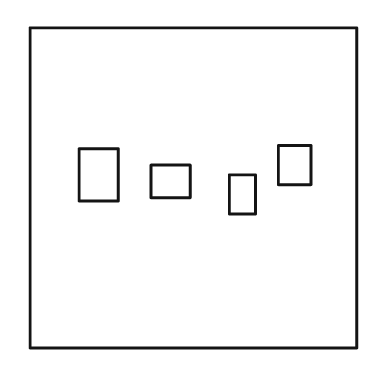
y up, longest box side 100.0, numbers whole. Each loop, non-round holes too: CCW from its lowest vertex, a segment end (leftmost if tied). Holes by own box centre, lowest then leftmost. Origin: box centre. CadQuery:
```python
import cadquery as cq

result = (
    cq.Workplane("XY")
    .moveTo(-50.0, -49.0)
    .lineTo(50.0, -49.0)
    .lineTo(50.0, 49.0)
    .lineTo(-50.0, 49.0)
    .close()
    .moveTo(11.0, -8.0)
    .lineTo(19.0, -8.0)
    .lineTo(19.0, 4.0)
    .lineTo(11.0, 4.0)
    .close()
    .moveTo(-13.0, -3.0)
    .lineTo(-1.0, -3.0)
    .lineTo(-1.0, 7.0)
    .lineTo(-13.0, 7.0)
    .close()
    .moveTo(-35.0, -4.0)
    .lineTo(-23.0, -4.0)
    .lineTo(-23.0, 12.0)
    .lineTo(-35.0, 12.0)
    .close()
    .moveTo(26.0, 1.0)
    .lineTo(36.0, 1.0)
    .lineTo(36.0, 13.0)
    .lineTo(26.0, 13.0)
    .close()
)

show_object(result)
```